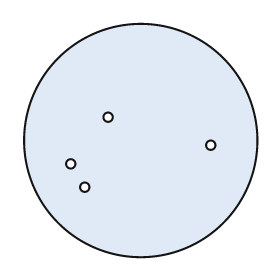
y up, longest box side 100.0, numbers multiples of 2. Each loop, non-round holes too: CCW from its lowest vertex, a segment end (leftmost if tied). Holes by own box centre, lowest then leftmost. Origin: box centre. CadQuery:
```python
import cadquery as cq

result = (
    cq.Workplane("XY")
    .moveTo(0.0, 0.0)
    .circle(50.0)
    .moveTo(-24.0, -20.0)
    .circle(2.0)
    .moveTo(-30.0, -10.0)
    .circle(2.0)
    .moveTo(30.0, -2.0)
    .circle(2.0)
    .moveTo(-14.0, 10.0)
    .circle(2.0)
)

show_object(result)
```